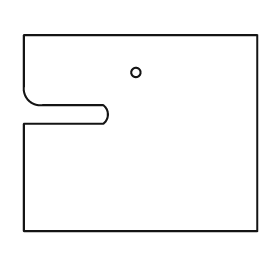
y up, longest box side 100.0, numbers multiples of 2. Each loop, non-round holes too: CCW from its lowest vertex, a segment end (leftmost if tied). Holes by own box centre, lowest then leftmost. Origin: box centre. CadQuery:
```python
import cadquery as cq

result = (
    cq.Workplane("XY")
    .moveTo(-50.0, -42.0)
    .lineTo(50.0, -42.0)
    .lineTo(50.0, 42.0)
    .lineTo(-50.0, 42.0)
    .lineTo(-50.0, 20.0)
    .threePointArc((-48.0, 14.0), (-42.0, 12.0))
    .lineTo(-16.0, 12.0)
    .threePointArc((-14.0, 8.0), (-16.0, 4.0))
    .lineTo(-50.0, 4.0)
    .close()
    .moveTo(-2.0, 26.0)
    .circle(2.0)
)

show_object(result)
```